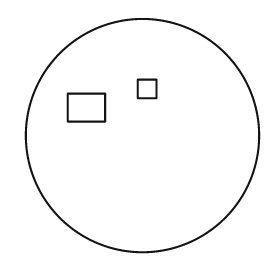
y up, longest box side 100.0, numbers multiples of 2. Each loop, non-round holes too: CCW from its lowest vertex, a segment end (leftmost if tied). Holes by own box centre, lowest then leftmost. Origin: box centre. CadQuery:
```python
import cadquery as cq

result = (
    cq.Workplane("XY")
    .moveTo(0.0, 0.0)
    .circle(50.0)
    .moveTo(-32.0, 6.0)
    .lineTo(-16.0, 6.0)
    .lineTo(-16.0, 18.0)
    .lineTo(-32.0, 18.0)
    .close()
    .moveTo(-2.0, 16.0)
    .lineTo(6.0, 16.0)
    .lineTo(6.0, 24.0)
    .lineTo(-2.0, 24.0)
    .close()
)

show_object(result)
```